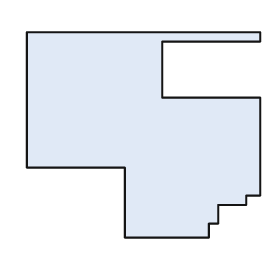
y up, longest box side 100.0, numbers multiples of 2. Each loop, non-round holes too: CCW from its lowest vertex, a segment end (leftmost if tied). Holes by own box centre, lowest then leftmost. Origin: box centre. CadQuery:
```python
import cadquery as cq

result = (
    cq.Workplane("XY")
    .moveTo(-8.0, -44.0)
    .lineTo(28.0, -44.0)
    .lineTo(28.0, -38.0)
    .lineTo(32.0, -38.0)
    .lineTo(32.0, -30.0)
    .lineTo(44.0, -30.0)
    .lineTo(44.0, -26.0)
    .lineTo(50.0, -26.0)
    .lineTo(50.0, 16.0)
    .lineTo(8.0, 16.0)
    .lineTo(8.0, 40.0)
    .lineTo(50.0, 40.0)
    .lineTo(50.0, 44.0)
    .lineTo(-50.0, 44.0)
    .lineTo(-50.0, -14.0)
    .lineTo(-8.0, -14.0)
    .close()
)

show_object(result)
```